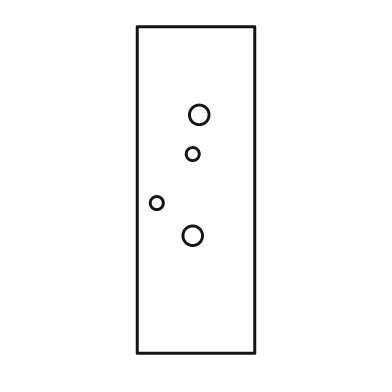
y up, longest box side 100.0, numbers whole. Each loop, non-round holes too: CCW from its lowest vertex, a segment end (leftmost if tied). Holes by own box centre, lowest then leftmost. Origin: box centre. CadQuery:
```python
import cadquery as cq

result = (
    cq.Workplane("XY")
    .moveTo(-18.0, -50.0)
    .lineTo(18.0, -50.0)
    .lineTo(18.0, 50.0)
    .lineTo(-18.0, 50.0)
    .close()
    .moveTo(-1.0, -14.0)
    .circle(3.0)
    .moveTo(-12.0, -4.0)
    .circle(2.0)
    .moveTo(-1.0, 11.0)
    .circle(2.0)
    .moveTo(1.0, 23.0)
    .circle(3.0)
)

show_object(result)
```